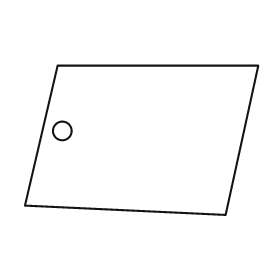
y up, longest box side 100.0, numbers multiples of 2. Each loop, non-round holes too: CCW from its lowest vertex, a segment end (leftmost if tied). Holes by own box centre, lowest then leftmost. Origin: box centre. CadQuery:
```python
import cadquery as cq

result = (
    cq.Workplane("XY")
    .moveTo(36.0, -32.0)
    .lineTo(50.0, 32.0)
    .lineTo(-36.0, 32.0)
    .lineTo(-50.0, -28.0)
    .close()
    .moveTo(-34.0, 4.0)
    .circle(4.0)
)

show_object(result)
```